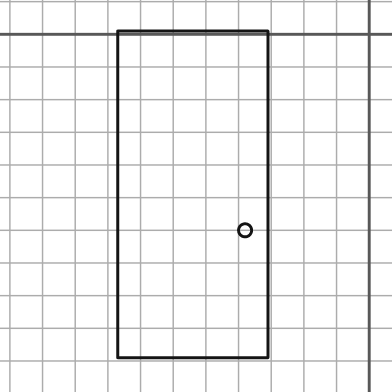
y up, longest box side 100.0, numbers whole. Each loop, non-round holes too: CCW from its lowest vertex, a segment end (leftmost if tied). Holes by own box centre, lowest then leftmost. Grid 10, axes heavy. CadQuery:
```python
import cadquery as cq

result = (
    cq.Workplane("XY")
    .moveTo(-77.0, -99.0)
    .lineTo(-31.0, -99.0)
    .lineTo(-31.0, 1.0)
    .lineTo(-77.0, 1.0)
    .close()
    .moveTo(-38.0, -60.0)
    .circle(2.0)
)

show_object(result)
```